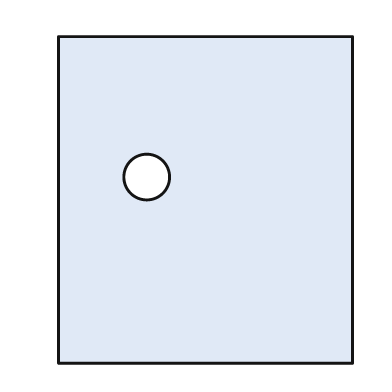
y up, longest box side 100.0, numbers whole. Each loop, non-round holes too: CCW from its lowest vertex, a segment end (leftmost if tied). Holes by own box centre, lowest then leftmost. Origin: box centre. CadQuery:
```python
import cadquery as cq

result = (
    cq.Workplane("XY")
    .moveTo(-45.0, -50.0)
    .lineTo(45.0, -50.0)
    .lineTo(45.0, 50.0)
    .lineTo(-45.0, 50.0)
    .close()
    .moveTo(-18.0, 7.0)
    .circle(7.0)
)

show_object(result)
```